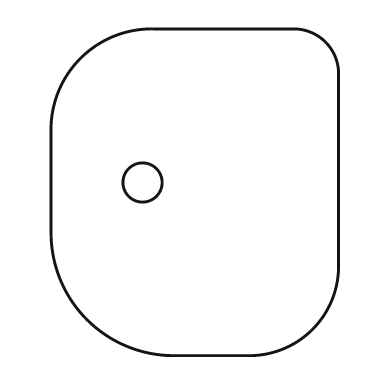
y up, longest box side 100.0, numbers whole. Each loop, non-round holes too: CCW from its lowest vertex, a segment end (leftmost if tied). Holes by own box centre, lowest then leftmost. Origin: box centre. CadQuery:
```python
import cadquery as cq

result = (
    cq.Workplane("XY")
    .moveTo(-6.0, -50.0)
    .lineTo(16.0, -50.0)
    .threePointArc((36.0, -42.0), (44.0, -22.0))
    .lineTo(44.0, 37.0)
    .threePointArc((40.0, 46.0), (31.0, 50.0))
    .lineTo(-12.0, 50.0)
    .threePointArc((-35.0, 41.0), (-44.0, 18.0))
    .lineTo(-44.0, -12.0)
    .threePointArc((-33.0, -39.0), (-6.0, -50.0))
    .close()
    .moveTo(-16.0, 3.0)
    .circle(6.0)
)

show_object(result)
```